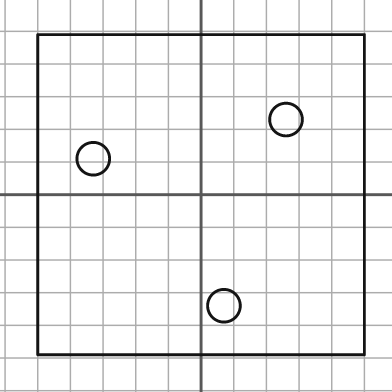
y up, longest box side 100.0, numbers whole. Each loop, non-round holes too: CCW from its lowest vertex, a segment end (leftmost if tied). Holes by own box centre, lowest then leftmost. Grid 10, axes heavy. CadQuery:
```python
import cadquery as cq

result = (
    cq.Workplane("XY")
    .moveTo(-50.0, -49.0)
    .lineTo(50.0, -49.0)
    .lineTo(50.0, 49.0)
    .lineTo(-50.0, 49.0)
    .close()
    .moveTo(7.0, -34.0)
    .circle(5.0)
    .moveTo(-33.0, 11.0)
    .circle(5.0)
    .moveTo(26.0, 23.0)
    .circle(5.0)
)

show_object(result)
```